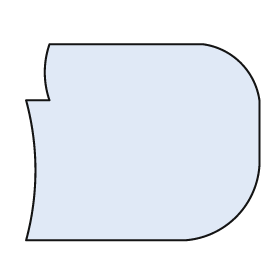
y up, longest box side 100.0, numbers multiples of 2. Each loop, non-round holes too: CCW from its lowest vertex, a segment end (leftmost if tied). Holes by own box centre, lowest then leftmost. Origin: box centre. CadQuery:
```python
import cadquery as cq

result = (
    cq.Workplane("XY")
    .moveTo(-50.0, -42.0)
    .lineTo(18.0, -42.0)
    .threePointArc((40.0, -32.0), (50.0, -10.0))
    .lineTo(50.0, 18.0)
    .threePointArc((42.0, 34.0), (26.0, 42.0))
    .lineTo(-40.0, 42.0)
    .threePointArc((-42.0, 30.0), (-40.0, 18.0))
    .lineTo(-50.0, 18.0)
    .threePointArc((-46.0, -12.0), (-50.0, -42.0))
    .close()
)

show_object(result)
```